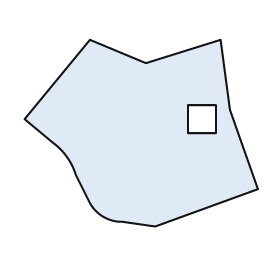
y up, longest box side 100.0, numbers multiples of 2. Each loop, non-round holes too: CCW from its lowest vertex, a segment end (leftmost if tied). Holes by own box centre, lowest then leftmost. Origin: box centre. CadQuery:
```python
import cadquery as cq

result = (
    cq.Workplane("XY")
    .moveTo(6.0, -40.0)
    .lineTo(50.0, -24.0)
    .lineTo(38.0, 10.0)
    .lineTo(34.0, 40.0)
    .lineTo(2.0, 30.0)
    .lineTo(-22.0, 40.0)
    .lineTo(-50.0, 6.0)
    .lineTo(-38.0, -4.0)
    .threePointArc((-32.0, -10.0), (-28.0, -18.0))
    .lineTo(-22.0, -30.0)
    .threePointArc((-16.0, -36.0), (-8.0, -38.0))
    .close()
    .moveTo(20.0, 0.0)
    .lineTo(32.0, 0.0)
    .lineTo(32.0, 12.0)
    .lineTo(20.0, 12.0)
    .close()
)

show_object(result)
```